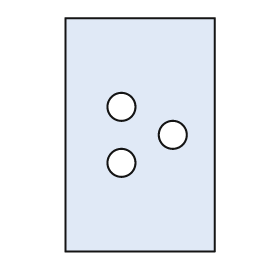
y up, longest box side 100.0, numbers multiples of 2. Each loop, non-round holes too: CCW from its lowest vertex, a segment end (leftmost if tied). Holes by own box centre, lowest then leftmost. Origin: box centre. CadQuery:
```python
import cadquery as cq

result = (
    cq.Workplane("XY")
    .moveTo(-32.0, -50.0)
    .lineTo(32.0, -50.0)
    .lineTo(32.0, 50.0)
    .lineTo(-32.0, 50.0)
    .close()
    .moveTo(-8.0, -12.0)
    .circle(6.0)
    .moveTo(14.0, 0.0)
    .circle(6.0)
    .moveTo(-8.0, 12.0)
    .circle(6.0)
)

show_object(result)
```